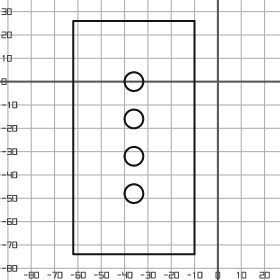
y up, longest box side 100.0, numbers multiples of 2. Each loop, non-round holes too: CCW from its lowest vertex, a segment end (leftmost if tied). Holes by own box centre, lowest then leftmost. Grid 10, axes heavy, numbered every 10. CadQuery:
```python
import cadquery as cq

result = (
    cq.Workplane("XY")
    .moveTo(-62.0, -74.0)
    .lineTo(-10.0, -74.0)
    .lineTo(-10.0, 26.0)
    .lineTo(-62.0, 26.0)
    .close()
    .moveTo(-36.0, -48.0)
    .circle(4.0)
    .moveTo(-36.0, -32.0)
    .circle(4.0)
    .moveTo(-36.0, -16.0)
    .circle(4.0)
    .moveTo(-36.0, 0.0)
    .circle(4.0)
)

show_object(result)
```